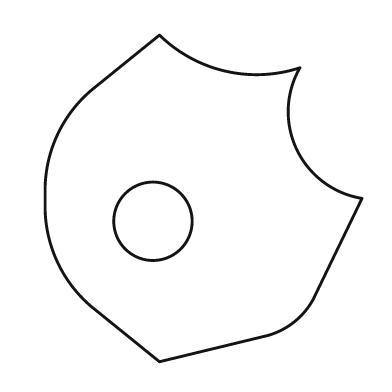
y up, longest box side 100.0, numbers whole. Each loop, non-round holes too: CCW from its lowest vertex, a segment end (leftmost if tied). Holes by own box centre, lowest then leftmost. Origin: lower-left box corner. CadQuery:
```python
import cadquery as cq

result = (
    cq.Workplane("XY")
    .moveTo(35.0, 0.0)
    .lineTo(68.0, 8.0)
    .threePointArc((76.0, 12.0), (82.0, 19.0))
    .lineTo(97.0, 50.0)
    .threePointArc((77.0, 65.0), (78.0, 90.0))
    .threePointArc((55.0, 89.0), (35.0, 100.0))
    .lineTo(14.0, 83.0)
    .threePointArc((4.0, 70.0), (0.0, 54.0))
    .lineTo(0.0, 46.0)
    .threePointArc((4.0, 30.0), (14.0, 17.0))
    .close()
    .moveTo(33.0, 43.0)
    .circle(12.0)
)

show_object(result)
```